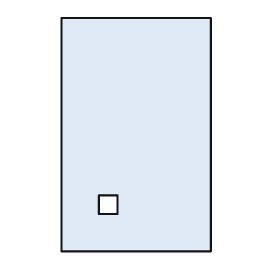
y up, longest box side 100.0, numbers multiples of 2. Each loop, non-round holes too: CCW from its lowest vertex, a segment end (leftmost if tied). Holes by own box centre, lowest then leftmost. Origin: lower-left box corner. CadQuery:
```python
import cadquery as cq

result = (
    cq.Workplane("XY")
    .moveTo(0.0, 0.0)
    .lineTo(64.0, 0.0)
    .lineTo(64.0, 100.0)
    .lineTo(0.0, 100.0)
    .close()
    .moveTo(16.0, 16.0)
    .lineTo(24.0, 16.0)
    .lineTo(24.0, 24.0)
    .lineTo(16.0, 24.0)
    .close()
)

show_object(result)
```